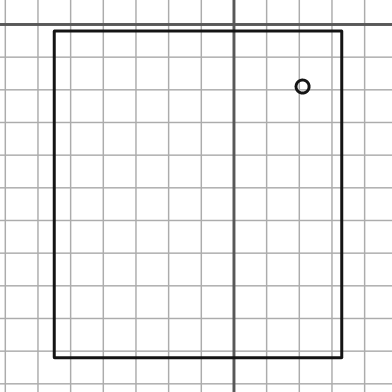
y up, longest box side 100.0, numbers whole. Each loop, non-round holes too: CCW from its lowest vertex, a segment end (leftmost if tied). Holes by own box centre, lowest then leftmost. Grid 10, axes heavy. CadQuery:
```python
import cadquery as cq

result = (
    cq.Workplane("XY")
    .moveTo(-55.0, -102.0)
    .lineTo(33.0, -102.0)
    .lineTo(33.0, -2.0)
    .lineTo(-55.0, -2.0)
    .close()
    .moveTo(21.0, -19.0)
    .circle(2.0)
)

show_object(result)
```